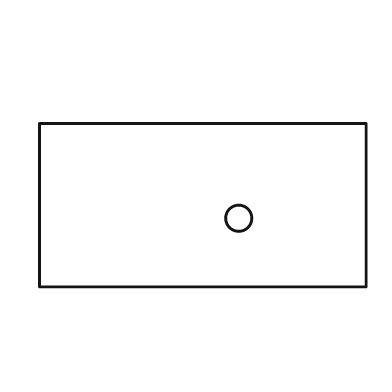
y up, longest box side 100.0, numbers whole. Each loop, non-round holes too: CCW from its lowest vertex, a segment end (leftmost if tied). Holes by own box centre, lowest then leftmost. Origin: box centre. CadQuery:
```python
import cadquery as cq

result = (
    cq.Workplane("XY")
    .moveTo(-50.0, -25.0)
    .lineTo(50.0, -25.0)
    .lineTo(50.0, 25.0)
    .lineTo(-50.0, 25.0)
    .close()
    .moveTo(11.0, -4.0)
    .circle(4.0)
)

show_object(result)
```